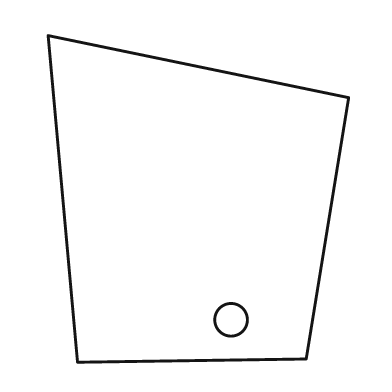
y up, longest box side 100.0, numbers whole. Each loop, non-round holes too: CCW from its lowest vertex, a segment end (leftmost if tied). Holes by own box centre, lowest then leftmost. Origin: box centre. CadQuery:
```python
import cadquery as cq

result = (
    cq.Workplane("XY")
    .moveTo(-37.0, -50.0)
    .lineTo(33.0, -49.0)
    .lineTo(46.0, 31.0)
    .lineTo(-46.0, 50.0)
    .close()
    .moveTo(10.0, -37.0)
    .circle(5.0)
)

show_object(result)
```